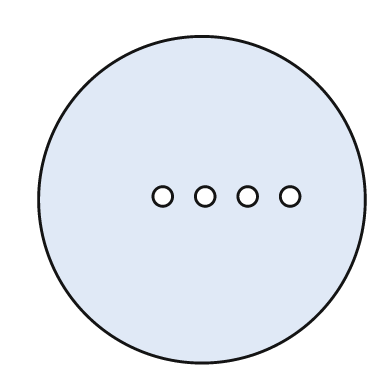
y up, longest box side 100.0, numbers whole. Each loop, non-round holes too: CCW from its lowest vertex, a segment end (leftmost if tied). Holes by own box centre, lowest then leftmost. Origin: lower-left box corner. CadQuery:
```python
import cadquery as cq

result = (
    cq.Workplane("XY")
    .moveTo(50.0, 50.0)
    .circle(50.0)
    .moveTo(38.0, 51.0)
    .circle(3.0)
    .moveTo(51.0, 51.0)
    .circle(3.0)
    .moveTo(64.0, 51.0)
    .circle(3.0)
    .moveTo(77.0, 51.0)
    .circle(3.0)
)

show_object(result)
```